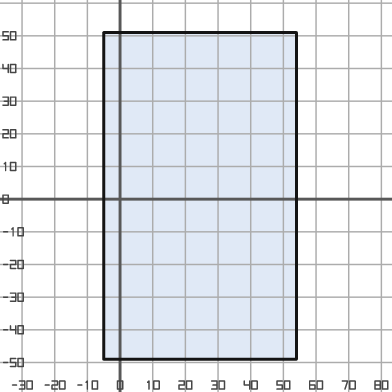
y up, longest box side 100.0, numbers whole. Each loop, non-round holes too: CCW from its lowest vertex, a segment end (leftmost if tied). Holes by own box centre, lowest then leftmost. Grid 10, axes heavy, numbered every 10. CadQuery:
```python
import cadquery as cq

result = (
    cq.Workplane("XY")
    .moveTo(-5.0, -49.0)
    .lineTo(54.0, -49.0)
    .lineTo(54.0, 51.0)
    .lineTo(-5.0, 51.0)
    .close()
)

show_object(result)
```